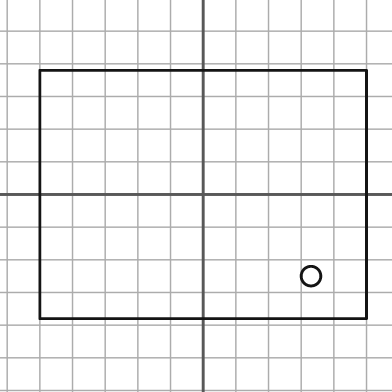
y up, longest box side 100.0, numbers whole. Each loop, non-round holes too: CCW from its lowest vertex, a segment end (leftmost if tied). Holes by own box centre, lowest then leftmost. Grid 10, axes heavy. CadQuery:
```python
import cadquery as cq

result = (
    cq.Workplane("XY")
    .moveTo(-50.0, -38.0)
    .lineTo(50.0, -38.0)
    .lineTo(50.0, 38.0)
    .lineTo(-50.0, 38.0)
    .close()
    .moveTo(33.0, -25.0)
    .circle(3.0)
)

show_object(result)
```